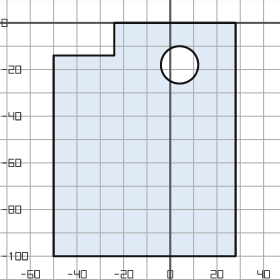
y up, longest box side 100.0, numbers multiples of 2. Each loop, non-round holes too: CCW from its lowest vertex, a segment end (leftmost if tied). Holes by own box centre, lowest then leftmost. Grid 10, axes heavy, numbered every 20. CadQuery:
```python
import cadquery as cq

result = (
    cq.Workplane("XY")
    .moveTo(-50.0, -100.0)
    .lineTo(28.0, -100.0)
    .lineTo(28.0, 0.0)
    .lineTo(-24.0, 0.0)
    .lineTo(-24.0, -14.0)
    .lineTo(-50.0, -14.0)
    .close()
    .moveTo(4.0, -18.0)
    .circle(8.0)
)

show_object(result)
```